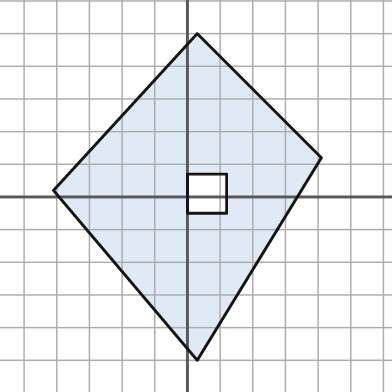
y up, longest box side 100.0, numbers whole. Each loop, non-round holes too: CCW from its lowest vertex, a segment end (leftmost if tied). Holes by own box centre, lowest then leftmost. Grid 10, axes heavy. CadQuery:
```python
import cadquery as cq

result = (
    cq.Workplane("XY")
    .moveTo(3.0, -50.0)
    .lineTo(41.0, 12.0)
    .lineTo(3.0, 50.0)
    .lineTo(-41.0, 2.0)
    .close()
    .moveTo(0.0, -5.0)
    .lineTo(12.0, -5.0)
    .lineTo(12.0, 7.0)
    .lineTo(0.0, 7.0)
    .close()
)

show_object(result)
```